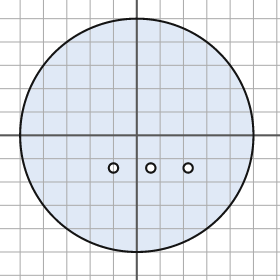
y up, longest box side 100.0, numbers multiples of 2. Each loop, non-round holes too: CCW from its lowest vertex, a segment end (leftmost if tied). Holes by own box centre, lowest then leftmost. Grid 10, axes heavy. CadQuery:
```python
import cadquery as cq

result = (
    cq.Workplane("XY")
    .moveTo(0.0, 0.0)
    .circle(50.0)
    .moveTo(-10.0, -14.0)
    .circle(2.0)
    .moveTo(6.0, -14.0)
    .circle(2.0)
    .moveTo(22.0, -14.0)
    .circle(2.0)
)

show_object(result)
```